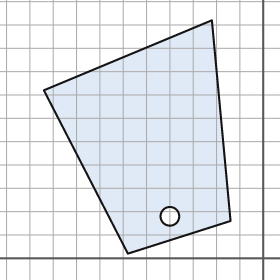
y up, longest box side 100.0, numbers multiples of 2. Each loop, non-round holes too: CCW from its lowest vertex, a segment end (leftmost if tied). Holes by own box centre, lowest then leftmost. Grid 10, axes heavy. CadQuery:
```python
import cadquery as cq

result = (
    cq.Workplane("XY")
    .moveTo(-58.0, 2.0)
    .lineTo(-14.0, 16.0)
    .lineTo(-22.0, 102.0)
    .lineTo(-94.0, 72.0)
    .close()
    .moveTo(-40.0, 18.0)
    .circle(4.0)
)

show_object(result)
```